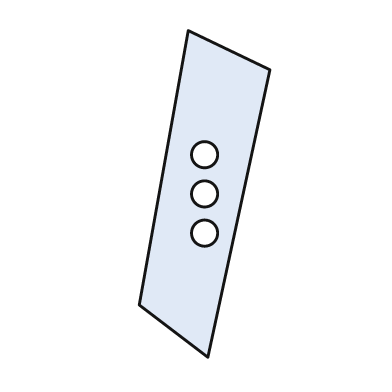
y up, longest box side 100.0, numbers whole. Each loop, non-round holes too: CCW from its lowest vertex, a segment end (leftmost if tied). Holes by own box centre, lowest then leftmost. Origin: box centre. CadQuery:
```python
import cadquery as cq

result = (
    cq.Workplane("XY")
    .moveTo(1.0, -50.0)
    .lineTo(20.0, 38.0)
    .lineTo(-5.0, 50.0)
    .lineTo(-20.0, -34.0)
    .close()
    .moveTo(0.0, -12.0)
    .circle(4.0)
    .moveTo(0.0, 0.0)
    .circle(4.0)
    .moveTo(0.0, 12.0)
    .circle(4.0)
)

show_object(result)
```